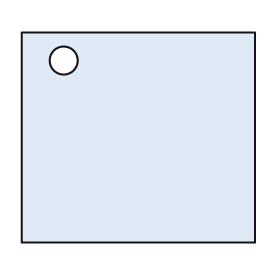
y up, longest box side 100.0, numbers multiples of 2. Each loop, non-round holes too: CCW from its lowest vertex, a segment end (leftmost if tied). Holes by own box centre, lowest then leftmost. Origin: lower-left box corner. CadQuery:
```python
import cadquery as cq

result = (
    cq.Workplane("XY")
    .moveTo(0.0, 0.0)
    .lineTo(100.0, 0.0)
    .lineTo(100.0, 90.0)
    .lineTo(0.0, 90.0)
    .close()
    .moveTo(18.0, 78.0)
    .circle(6.0)
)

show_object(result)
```